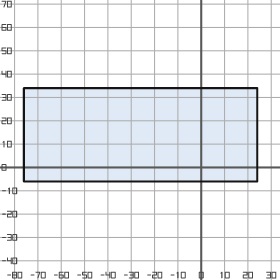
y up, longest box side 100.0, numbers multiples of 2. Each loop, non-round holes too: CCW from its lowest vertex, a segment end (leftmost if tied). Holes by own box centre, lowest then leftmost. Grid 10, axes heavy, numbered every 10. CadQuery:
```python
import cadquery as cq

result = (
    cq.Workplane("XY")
    .moveTo(-76.0, -6.0)
    .lineTo(24.0, -6.0)
    .lineTo(24.0, 34.0)
    .lineTo(-76.0, 34.0)
    .close()
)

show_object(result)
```